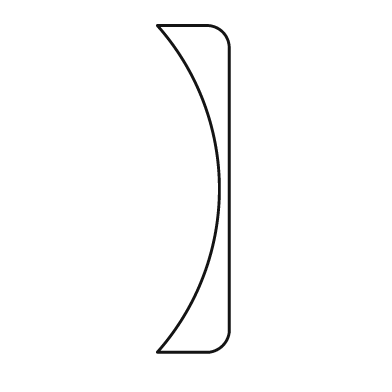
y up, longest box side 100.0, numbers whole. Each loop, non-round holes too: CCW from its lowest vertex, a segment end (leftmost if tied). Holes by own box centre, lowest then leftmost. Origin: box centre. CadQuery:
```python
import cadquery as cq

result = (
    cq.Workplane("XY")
    .moveTo(-11.0, -50.0)
    .lineTo(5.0, -50.0)
    .threePointArc((9.0, -48.0), (11.0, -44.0))
    .lineTo(11.0, 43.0)
    .threePointArc((9.0, 48.0), (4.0, 50.0))
    .lineTo(-11.0, 50.0)
    .threePointArc((8.0, 0.0), (-11.0, -50.0))
    .close()
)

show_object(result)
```